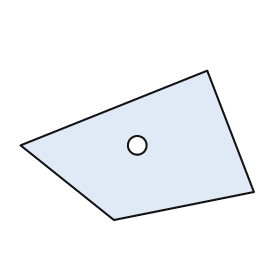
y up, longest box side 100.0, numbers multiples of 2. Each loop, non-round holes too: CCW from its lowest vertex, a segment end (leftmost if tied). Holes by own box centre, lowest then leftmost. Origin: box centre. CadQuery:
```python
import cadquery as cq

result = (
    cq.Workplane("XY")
    .moveTo(-10.0, -32.0)
    .lineTo(50.0, -20.0)
    .lineTo(30.0, 32.0)
    .lineTo(-50.0, 0.0)
    .close()
    .moveTo(0.0, 0.0)
    .circle(4.0)
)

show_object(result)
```